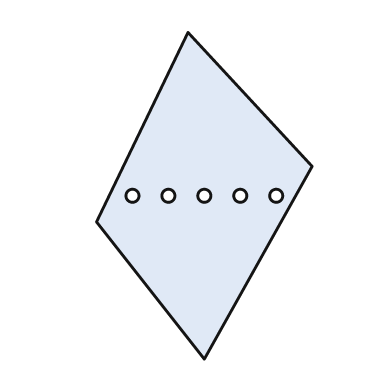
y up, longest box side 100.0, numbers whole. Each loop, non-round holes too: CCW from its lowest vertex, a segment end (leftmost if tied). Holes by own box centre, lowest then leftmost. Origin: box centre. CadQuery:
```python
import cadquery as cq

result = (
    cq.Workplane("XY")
    .moveTo(0.0, -50.0)
    .lineTo(33.0, 9.0)
    .lineTo(-5.0, 50.0)
    .lineTo(-33.0, -8.0)
    .close()
    .moveTo(-22.0, 0.0)
    .circle(2.0)
    .moveTo(-11.0, 0.0)
    .circle(2.0)
    .moveTo(0.0, 0.0)
    .circle(2.0)
    .moveTo(11.0, 0.0)
    .circle(2.0)
    .moveTo(22.0, 0.0)
    .circle(2.0)
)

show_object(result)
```